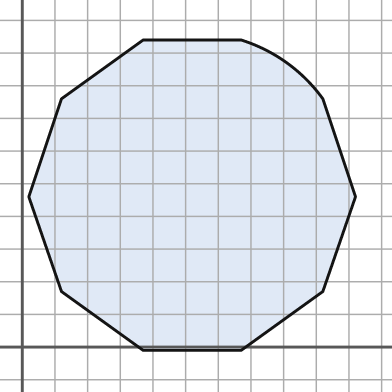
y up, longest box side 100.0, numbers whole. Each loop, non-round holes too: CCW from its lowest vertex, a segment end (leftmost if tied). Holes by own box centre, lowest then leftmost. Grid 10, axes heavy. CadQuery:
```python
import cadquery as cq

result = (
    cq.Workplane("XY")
    .moveTo(37.0, -1.0)
    .lineTo(67.0, -1.0)
    .lineTo(92.0, 17.0)
    .lineTo(102.0, 46.0)
    .lineTo(92.0, 76.0)
    .threePointArc((81.0, 87.0), (67.0, 94.0))
    .lineTo(37.0, 94.0)
    .lineTo(12.0, 76.0)
    .lineTo(2.0, 46.0)
    .lineTo(12.0, 17.0)
    .close()
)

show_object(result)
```